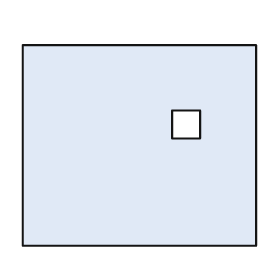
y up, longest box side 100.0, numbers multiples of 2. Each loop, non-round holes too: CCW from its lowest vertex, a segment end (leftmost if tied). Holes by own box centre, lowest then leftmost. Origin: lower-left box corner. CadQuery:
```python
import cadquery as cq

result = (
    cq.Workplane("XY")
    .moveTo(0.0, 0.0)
    .lineTo(100.0, 0.0)
    .lineTo(100.0, 86.0)
    .lineTo(0.0, 86.0)
    .close()
    .moveTo(64.0, 46.0)
    .lineTo(76.0, 46.0)
    .lineTo(76.0, 58.0)
    .lineTo(64.0, 58.0)
    .close()
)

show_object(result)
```